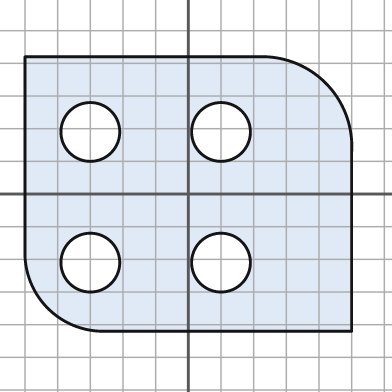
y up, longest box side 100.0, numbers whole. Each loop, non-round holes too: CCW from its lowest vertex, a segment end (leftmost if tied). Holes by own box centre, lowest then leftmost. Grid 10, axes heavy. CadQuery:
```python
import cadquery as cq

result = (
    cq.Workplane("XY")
    .moveTo(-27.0, -42.0)
    .lineTo(50.0, -42.0)
    .lineTo(50.0, 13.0)
    .threePointArc((42.0, 34.0), (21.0, 42.0))
    .lineTo(-50.0, 42.0)
    .lineTo(-50.0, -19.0)
    .threePointArc((-43.0, -35.0), (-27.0, -42.0))
    .close()
    .moveTo(-30.0, -21.0)
    .circle(9.0)
    .moveTo(10.0, -21.0)
    .circle(9.0)
    .moveTo(-30.0, 19.0)
    .circle(9.0)
    .moveTo(10.0, 19.0)
    .circle(9.0)
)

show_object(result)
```